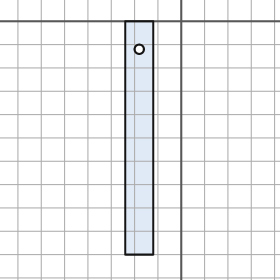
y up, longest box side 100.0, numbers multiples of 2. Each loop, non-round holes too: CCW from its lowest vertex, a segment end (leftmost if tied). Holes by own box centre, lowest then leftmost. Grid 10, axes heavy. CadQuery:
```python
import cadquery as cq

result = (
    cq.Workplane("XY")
    .moveTo(-24.0, -100.0)
    .lineTo(-12.0, -100.0)
    .lineTo(-12.0, 0.0)
    .lineTo(-24.0, 0.0)
    .close()
    .moveTo(-18.0, -12.0)
    .circle(2.0)
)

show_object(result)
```